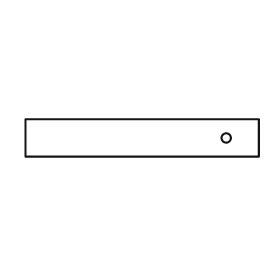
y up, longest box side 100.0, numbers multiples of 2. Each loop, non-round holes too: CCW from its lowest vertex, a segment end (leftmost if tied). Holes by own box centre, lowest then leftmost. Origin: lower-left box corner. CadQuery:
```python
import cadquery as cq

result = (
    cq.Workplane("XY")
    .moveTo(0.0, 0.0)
    .lineTo(100.0, 0.0)
    .lineTo(100.0, 16.0)
    .lineTo(0.0, 16.0)
    .close()
    .moveTo(86.0, 8.0)
    .circle(2.0)
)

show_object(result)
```